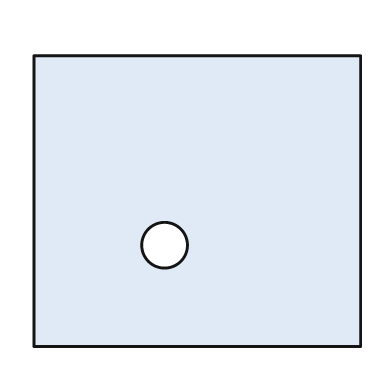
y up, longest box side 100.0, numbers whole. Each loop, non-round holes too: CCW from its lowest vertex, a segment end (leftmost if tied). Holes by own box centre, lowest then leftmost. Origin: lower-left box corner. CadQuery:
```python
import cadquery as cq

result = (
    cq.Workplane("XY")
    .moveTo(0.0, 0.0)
    .lineTo(100.0, 0.0)
    .lineTo(100.0, 89.0)
    .lineTo(0.0, 89.0)
    .close()
    .moveTo(40.0, 31.0)
    .circle(7.0)
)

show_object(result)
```